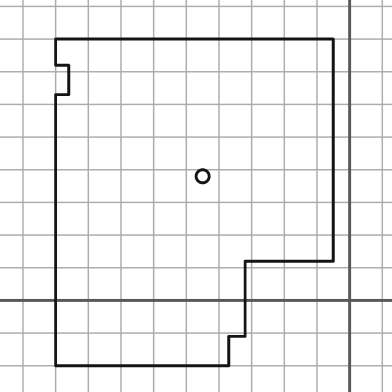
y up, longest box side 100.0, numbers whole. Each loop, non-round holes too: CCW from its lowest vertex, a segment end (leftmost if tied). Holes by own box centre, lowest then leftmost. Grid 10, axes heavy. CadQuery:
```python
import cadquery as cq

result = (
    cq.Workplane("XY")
    .moveTo(-90.0, -20.0)
    .lineTo(-37.0, -20.0)
    .lineTo(-37.0, -11.0)
    .lineTo(-32.0, -11.0)
    .lineTo(-32.0, 12.0)
    .lineTo(-5.0, 12.0)
    .lineTo(-5.0, 80.0)
    .lineTo(-90.0, 80.0)
    .lineTo(-90.0, 72.0)
    .lineTo(-86.0, 72.0)
    .lineTo(-86.0, 63.0)
    .lineTo(-90.0, 63.0)
    .close()
    .moveTo(-45.0, 38.0)
    .circle(2.0)
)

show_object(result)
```